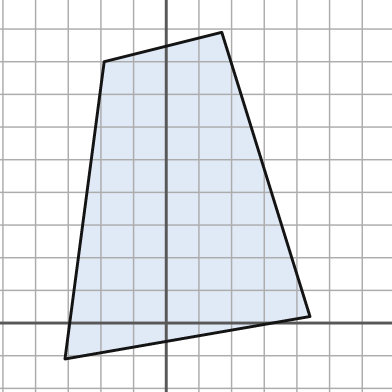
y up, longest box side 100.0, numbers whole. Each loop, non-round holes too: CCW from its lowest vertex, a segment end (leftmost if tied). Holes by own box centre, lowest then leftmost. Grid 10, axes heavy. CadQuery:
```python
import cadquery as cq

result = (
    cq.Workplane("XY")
    .moveTo(-31.0, -11.0)
    .lineTo(44.0, 2.0)
    .lineTo(17.0, 89.0)
    .lineTo(-19.0, 80.0)
    .close()
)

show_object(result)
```